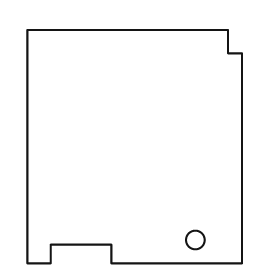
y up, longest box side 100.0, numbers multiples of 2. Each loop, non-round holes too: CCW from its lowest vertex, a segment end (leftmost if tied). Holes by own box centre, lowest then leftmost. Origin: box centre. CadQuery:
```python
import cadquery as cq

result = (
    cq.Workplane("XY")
    .moveTo(-46.0, -50.0)
    .lineTo(-36.0, -50.0)
    .lineTo(-36.0, -42.0)
    .lineTo(-10.0, -42.0)
    .lineTo(-10.0, -50.0)
    .lineTo(46.0, -50.0)
    .lineTo(46.0, 40.0)
    .lineTo(40.0, 40.0)
    .lineTo(40.0, 50.0)
    .lineTo(-46.0, 50.0)
    .close()
    .moveTo(26.0, -40.0)
    .circle(4.0)
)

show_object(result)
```